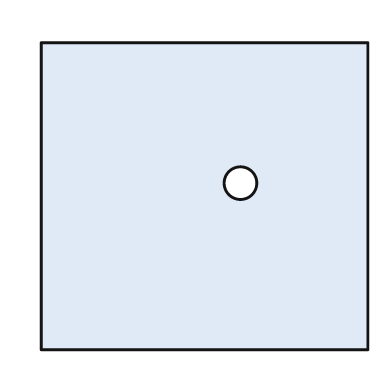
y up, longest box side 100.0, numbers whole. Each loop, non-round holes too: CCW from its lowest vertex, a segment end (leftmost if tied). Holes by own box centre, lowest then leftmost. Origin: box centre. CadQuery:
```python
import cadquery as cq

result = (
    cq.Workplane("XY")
    .moveTo(-50.0, -47.0)
    .lineTo(50.0, -47.0)
    .lineTo(50.0, 47.0)
    .lineTo(-50.0, 47.0)
    .close()
    .moveTo(11.0, 4.0)
    .circle(5.0)
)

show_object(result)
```